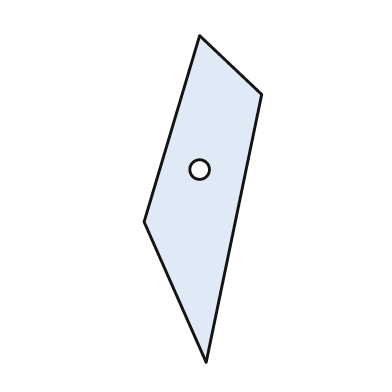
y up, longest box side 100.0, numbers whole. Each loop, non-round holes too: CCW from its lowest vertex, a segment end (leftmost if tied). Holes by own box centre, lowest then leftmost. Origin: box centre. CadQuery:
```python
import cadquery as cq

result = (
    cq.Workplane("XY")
    .moveTo(1.0, -50.0)
    .lineTo(18.0, 32.0)
    .lineTo(-1.0, 50.0)
    .lineTo(-18.0, -7.0)
    .close()
    .moveTo(-1.0, 9.0)
    .circle(3.0)
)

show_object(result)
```